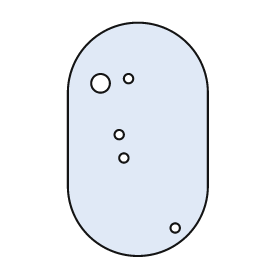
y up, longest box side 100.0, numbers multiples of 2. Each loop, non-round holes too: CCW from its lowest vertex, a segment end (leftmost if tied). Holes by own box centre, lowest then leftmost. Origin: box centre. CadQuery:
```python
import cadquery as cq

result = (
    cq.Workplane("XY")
    .moveTo(-30.0, -20.0)
    .threePointArc((0.0, -50.0), (30.0, -20.0))
    .lineTo(30.0, 20.0)
    .threePointArc((0.0, 50.0), (-30.0, 20.0))
    .close()
    .moveTo(16.0, -38.0)
    .circle(2.0)
    .moveTo(-6.0, -8.0)
    .circle(2.0)
    .moveTo(-8.0, 2.0)
    .circle(2.0)
    .moveTo(-16.0, 24.0)
    .circle(4.0)
    .moveTo(-4.0, 26.0)
    .circle(2.0)
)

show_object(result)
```